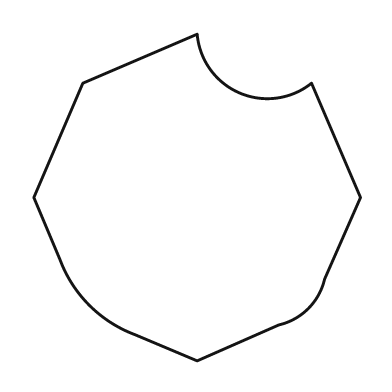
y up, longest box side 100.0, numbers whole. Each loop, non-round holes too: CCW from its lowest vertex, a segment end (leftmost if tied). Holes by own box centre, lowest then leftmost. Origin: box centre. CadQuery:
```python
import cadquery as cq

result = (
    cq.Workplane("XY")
    .moveTo(0.0, -50.0)
    .lineTo(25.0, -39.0)
    .threePointArc((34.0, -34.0), (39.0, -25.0))
    .lineTo(50.0, 0.0)
    .lineTo(35.0, 35.0)
    .threePointArc((13.0, 32.0), (0.0, 50.0))
    .lineTo(-35.0, 35.0)
    .lineTo(-50.0, 0.0)
    .lineTo(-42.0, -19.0)
    .threePointArc((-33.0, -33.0), (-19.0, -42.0))
    .close()
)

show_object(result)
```